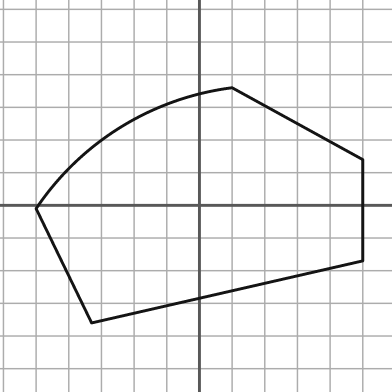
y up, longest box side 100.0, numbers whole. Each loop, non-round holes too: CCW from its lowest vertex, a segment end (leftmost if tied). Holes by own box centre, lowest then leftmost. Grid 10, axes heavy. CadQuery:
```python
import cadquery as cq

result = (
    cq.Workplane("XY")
    .moveTo(-33.0, -36.0)
    .lineTo(50.0, -17.0)
    .lineTo(50.0, 14.0)
    .lineTo(10.0, 36.0)
    .threePointArc((-24.0, 24.0), (-50.0, -1.0))
    .close()
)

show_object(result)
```